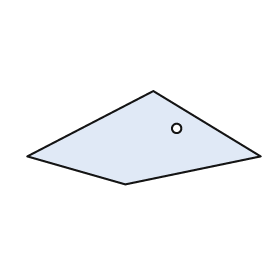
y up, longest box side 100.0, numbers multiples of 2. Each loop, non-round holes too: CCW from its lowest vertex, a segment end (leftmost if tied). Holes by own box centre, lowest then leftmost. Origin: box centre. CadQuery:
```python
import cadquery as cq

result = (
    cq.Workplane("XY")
    .moveTo(-8.0, -20.0)
    .lineTo(50.0, -8.0)
    .lineTo(4.0, 20.0)
    .lineTo(-50.0, -8.0)
    .close()
    .moveTo(14.0, 4.0)
    .circle(2.0)
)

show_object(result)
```